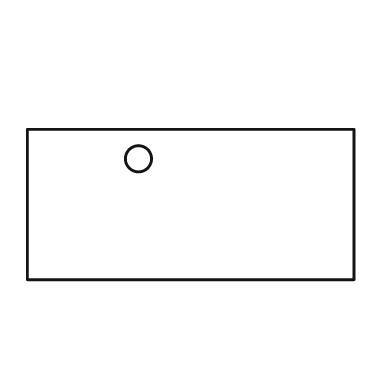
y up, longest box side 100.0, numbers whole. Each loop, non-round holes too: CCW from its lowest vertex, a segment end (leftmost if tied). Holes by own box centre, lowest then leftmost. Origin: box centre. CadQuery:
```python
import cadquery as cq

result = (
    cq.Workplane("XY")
    .moveTo(-50.0, -23.0)
    .lineTo(50.0, -23.0)
    .lineTo(50.0, 23.0)
    .lineTo(-50.0, 23.0)
    .close()
    .moveTo(-16.0, 14.0)
    .circle(4.0)
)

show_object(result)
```